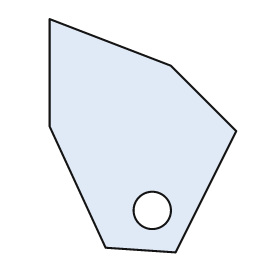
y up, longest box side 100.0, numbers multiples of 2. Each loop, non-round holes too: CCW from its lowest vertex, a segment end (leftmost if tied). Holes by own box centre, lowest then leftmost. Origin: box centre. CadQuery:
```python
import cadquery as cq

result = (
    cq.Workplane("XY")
    .moveTo(14.0, -50.0)
    .lineTo(40.0, 2.0)
    .lineTo(12.0, 30.0)
    .lineTo(-40.0, 50.0)
    .lineTo(-40.0, 4.0)
    .lineTo(-16.0, -48.0)
    .close()
    .moveTo(4.0, -32.0)
    .circle(8.0)
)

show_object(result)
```